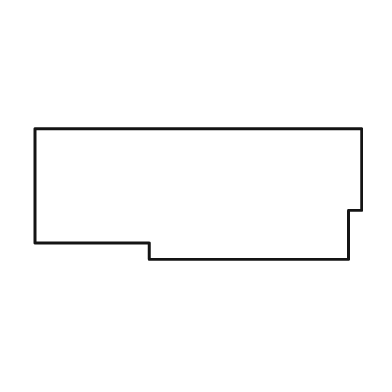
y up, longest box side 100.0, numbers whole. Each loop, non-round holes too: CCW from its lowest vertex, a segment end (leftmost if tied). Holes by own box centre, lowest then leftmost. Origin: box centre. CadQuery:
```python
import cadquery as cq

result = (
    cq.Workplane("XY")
    .moveTo(-15.0, -20.0)
    .lineTo(46.0, -20.0)
    .lineTo(46.0, -5.0)
    .lineTo(50.0, -5.0)
    .lineTo(50.0, 20.0)
    .lineTo(-50.0, 20.0)
    .lineTo(-50.0, -15.0)
    .lineTo(-15.0, -15.0)
    .close()
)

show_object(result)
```